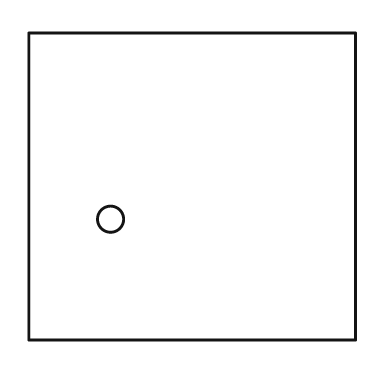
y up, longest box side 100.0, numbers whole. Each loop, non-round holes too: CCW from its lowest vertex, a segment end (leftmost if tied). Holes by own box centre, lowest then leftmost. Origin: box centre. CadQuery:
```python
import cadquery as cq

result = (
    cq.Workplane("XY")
    .moveTo(-50.0, -47.0)
    .lineTo(50.0, -47.0)
    .lineTo(50.0, 47.0)
    .lineTo(-50.0, 47.0)
    .close()
    .moveTo(-25.0, -10.0)
    .circle(4.0)
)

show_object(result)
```